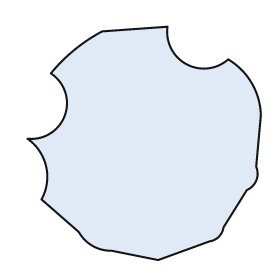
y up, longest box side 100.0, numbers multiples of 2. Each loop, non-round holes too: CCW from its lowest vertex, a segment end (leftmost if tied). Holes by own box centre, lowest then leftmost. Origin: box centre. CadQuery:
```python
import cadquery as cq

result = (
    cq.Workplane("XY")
    .moveTo(6.0, -50.0)
    .lineTo(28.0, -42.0)
    .threePointArc((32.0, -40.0), (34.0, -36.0))
    .lineTo(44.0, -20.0)
    .threePointArc((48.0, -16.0), (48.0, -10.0))
    .lineTo(50.0, 12.0)
    .threePointArc((46.0, 26.0), (36.0, 36.0))
    .threePointArc((18.0, 34.0), (10.0, 50.0))
    .lineTo(-18.0, 48.0)
    .threePointArc((-30.0, 40.0), (-40.0, 30.0))
    .threePointArc((-34.0, 12.0), (-50.0, 2.0))
    .threePointArc((-42.0, -10.0), (-44.0, -24.0))
    .lineTo(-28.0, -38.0)
    .threePointArc((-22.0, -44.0), (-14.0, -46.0))
    .close()
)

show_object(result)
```